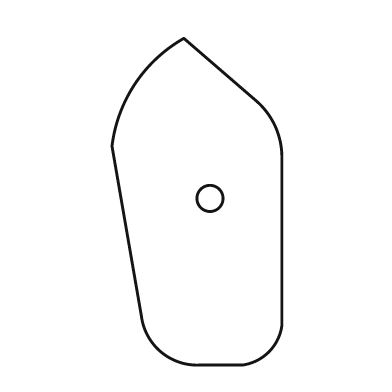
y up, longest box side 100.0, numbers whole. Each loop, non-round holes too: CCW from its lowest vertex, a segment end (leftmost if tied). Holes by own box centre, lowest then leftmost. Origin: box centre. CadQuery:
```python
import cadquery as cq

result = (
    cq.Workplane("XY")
    .moveTo(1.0, -50.0)
    .lineTo(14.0, -50.0)
    .threePointArc((22.0, -46.0), (26.0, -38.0))
    .lineTo(26.0, 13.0)
    .threePointArc((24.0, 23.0), (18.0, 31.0))
    .lineTo(-4.0, 50.0)
    .threePointArc((-19.0, 36.0), (-26.0, 17.0))
    .lineTo(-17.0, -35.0)
    .threePointArc((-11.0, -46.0), (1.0, -50.0))
    .close()
    .moveTo(4.0, 1.0)
    .circle(4.0)
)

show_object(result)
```